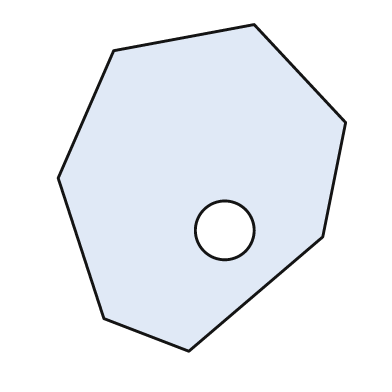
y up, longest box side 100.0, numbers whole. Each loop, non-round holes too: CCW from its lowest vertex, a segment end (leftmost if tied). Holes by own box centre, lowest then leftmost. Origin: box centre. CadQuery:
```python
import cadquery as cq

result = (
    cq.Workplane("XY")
    .moveTo(-4.0, -50.0)
    .lineTo(37.0, -15.0)
    .lineTo(44.0, 20.0)
    .lineTo(16.0, 50.0)
    .lineTo(-27.0, 42.0)
    .lineTo(-44.0, 3.0)
    .lineTo(-30.0, -40.0)
    .close()
    .moveTo(7.0, -13.0)
    .circle(9.0)
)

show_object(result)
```